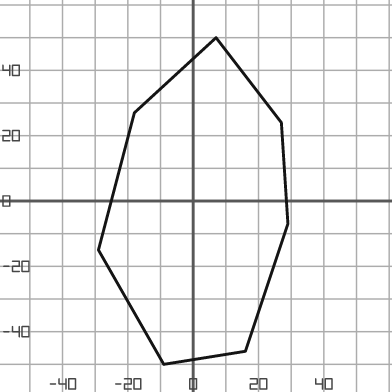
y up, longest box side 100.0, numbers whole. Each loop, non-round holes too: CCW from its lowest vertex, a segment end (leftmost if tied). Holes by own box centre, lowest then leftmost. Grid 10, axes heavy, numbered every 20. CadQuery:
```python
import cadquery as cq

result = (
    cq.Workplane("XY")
    .moveTo(-9.0, -50.0)
    .lineTo(16.0, -46.0)
    .lineTo(29.0, -7.0)
    .lineTo(27.0, 24.0)
    .lineTo(7.0, 50.0)
    .lineTo(-18.0, 27.0)
    .lineTo(-29.0, -15.0)
    .close()
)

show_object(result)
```